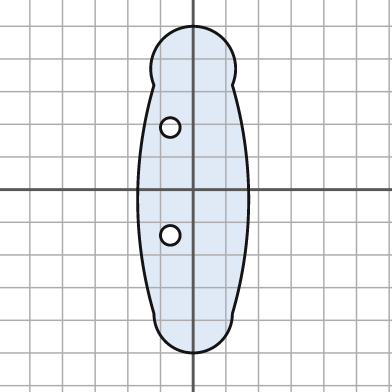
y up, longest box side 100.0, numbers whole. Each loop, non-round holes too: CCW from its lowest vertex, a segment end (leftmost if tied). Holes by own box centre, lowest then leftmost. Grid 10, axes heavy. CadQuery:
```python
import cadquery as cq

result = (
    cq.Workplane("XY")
    .moveTo(-12.0, -38.0)
    .threePointArc((0.0, -50.0), (12.0, -38.0))
    .threePointArc((17.0, -3.0), (12.0, 32.0))
    .threePointArc((0.0, 50.0), (-12.0, 32.0))
    .threePointArc((-17.0, -3.0), (-12.0, -38.0))
    .close()
    .moveTo(-7.0, -14.0)
    .circle(3.0)
    .moveTo(-7.0, 19.0)
    .circle(3.0)
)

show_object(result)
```